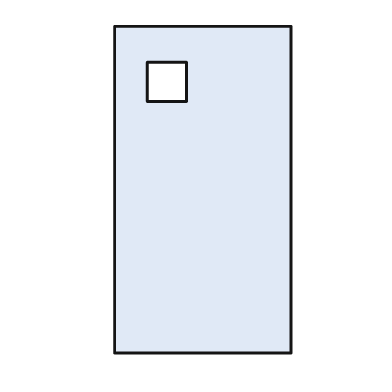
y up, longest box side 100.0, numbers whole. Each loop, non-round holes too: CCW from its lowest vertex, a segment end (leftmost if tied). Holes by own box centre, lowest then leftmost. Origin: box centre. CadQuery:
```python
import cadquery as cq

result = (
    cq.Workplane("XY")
    .moveTo(-27.0, -50.0)
    .lineTo(27.0, -50.0)
    .lineTo(27.0, 50.0)
    .lineTo(-27.0, 50.0)
    .close()
    .moveTo(-17.0, 27.0)
    .lineTo(-5.0, 27.0)
    .lineTo(-5.0, 39.0)
    .lineTo(-17.0, 39.0)
    .close()
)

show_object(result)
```